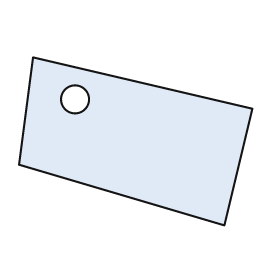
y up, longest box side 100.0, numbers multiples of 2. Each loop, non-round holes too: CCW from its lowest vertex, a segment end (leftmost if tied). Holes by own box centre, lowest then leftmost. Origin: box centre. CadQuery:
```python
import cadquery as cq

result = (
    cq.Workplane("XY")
    .moveTo(38.0, -36.0)
    .lineTo(50.0, 14.0)
    .lineTo(-44.0, 36.0)
    .lineTo(-50.0, -10.0)
    .close()
    .moveTo(-26.0, 18.0)
    .circle(6.0)
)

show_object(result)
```